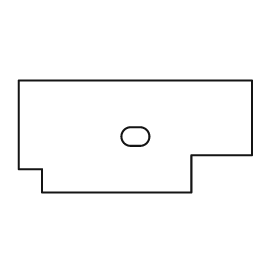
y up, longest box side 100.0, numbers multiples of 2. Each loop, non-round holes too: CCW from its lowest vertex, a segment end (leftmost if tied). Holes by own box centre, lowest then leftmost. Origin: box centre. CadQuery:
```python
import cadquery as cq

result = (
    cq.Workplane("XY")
    .moveTo(-40.0, -24.0)
    .lineTo(24.0, -24.0)
    .lineTo(24.0, -8.0)
    .lineTo(50.0, -8.0)
    .lineTo(50.0, 24.0)
    .lineTo(-50.0, 24.0)
    .lineTo(-50.0, -14.0)
    .lineTo(-40.0, -14.0)
    .close()
    .moveTo(-2.0, -4.0)
    .lineTo(2.0, -4.0)
    .threePointArc((6.0, 0.0), (2.0, 4.0))
    .lineTo(-2.0, 4.0)
    .threePointArc((-6.0, 0.0), (-2.0, -4.0))
    .close()
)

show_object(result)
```